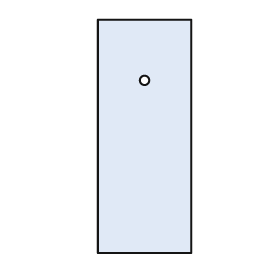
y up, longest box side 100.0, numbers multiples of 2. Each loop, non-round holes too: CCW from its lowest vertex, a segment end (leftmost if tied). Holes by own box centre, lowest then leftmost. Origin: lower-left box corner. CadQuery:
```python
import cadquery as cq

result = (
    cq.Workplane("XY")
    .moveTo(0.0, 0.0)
    .lineTo(40.0, 0.0)
    .lineTo(40.0, 100.0)
    .lineTo(0.0, 100.0)
    .close()
    .moveTo(20.0, 74.0)
    .circle(2.0)
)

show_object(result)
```